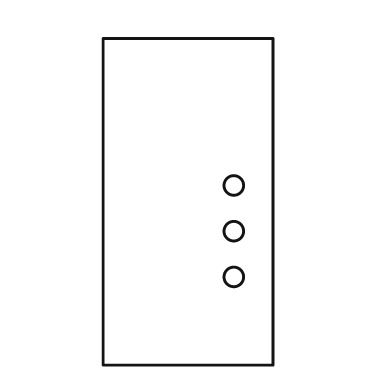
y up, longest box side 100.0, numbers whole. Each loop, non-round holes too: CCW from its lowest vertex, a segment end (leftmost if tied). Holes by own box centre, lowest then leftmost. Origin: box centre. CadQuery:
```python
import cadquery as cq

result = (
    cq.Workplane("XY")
    .moveTo(-26.0, -50.0)
    .lineTo(26.0, -50.0)
    .lineTo(26.0, 50.0)
    .lineTo(-26.0, 50.0)
    .close()
    .moveTo(14.0, -23.0)
    .circle(3.0)
    .moveTo(14.0, -9.0)
    .circle(3.0)
    .moveTo(14.0, 5.0)
    .circle(3.0)
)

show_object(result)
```